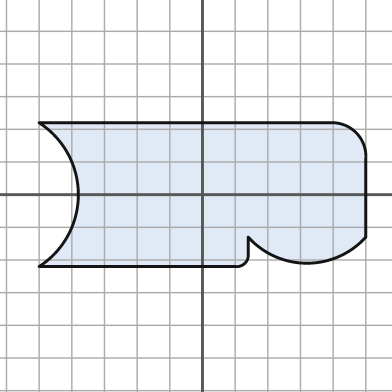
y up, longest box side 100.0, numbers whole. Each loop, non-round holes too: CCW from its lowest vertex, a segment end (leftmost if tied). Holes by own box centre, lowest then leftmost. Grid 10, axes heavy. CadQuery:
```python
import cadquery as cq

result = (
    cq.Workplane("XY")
    .moveTo(-50.0, -22.0)
    .lineTo(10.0, -22.0)
    .threePointArc((13.0, -21.0), (14.0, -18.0))
    .lineTo(14.0, -13.0)
    .threePointArc((32.0, -21.0), (50.0, -13.0))
    .lineTo(50.0, 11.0)
    .threePointArc((47.0, 19.0), (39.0, 22.0))
    .lineTo(-50.0, 22.0)
    .threePointArc((-38.0, 0.0), (-50.0, -22.0))
    .close()
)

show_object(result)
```